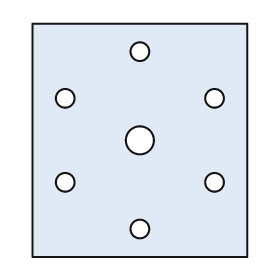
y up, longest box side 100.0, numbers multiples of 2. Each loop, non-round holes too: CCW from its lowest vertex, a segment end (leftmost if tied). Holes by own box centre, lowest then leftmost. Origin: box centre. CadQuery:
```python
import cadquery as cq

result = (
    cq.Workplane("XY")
    .moveTo(-46.0, -50.0)
    .lineTo(46.0, -50.0)
    .lineTo(46.0, 50.0)
    .lineTo(-46.0, 50.0)
    .close()
    .moveTo(0.0, -38.0)
    .circle(4.0)
    .moveTo(-32.0, -18.0)
    .circle(4.0)
    .moveTo(32.0, -18.0)
    .circle(4.0)
    .moveTo(0.0, 0.0)
    .circle(6.0)
    .moveTo(-32.0, 18.0)
    .circle(4.0)
    .moveTo(32.0, 18.0)
    .circle(4.0)
    .moveTo(0.0, 38.0)
    .circle(4.0)
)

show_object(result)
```